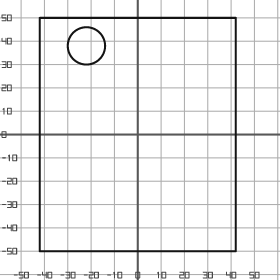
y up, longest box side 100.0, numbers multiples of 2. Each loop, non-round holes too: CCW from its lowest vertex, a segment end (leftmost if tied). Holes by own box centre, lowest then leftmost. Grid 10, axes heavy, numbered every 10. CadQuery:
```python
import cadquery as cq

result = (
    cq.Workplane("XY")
    .moveTo(-42.0, -50.0)
    .lineTo(42.0, -50.0)
    .lineTo(42.0, 50.0)
    .lineTo(-42.0, 50.0)
    .close()
    .moveTo(-22.0, 38.0)
    .circle(8.0)
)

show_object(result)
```